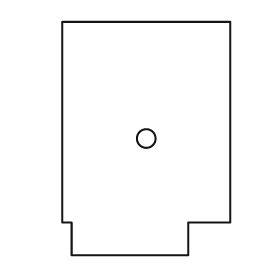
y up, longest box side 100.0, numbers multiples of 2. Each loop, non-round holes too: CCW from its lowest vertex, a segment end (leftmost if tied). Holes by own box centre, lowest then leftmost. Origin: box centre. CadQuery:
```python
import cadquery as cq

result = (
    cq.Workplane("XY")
    .moveTo(-32.0, -50.0)
    .lineTo(18.0, -50.0)
    .lineTo(18.0, -36.0)
    .lineTo(36.0, -36.0)
    .lineTo(36.0, 50.0)
    .lineTo(-36.0, 50.0)
    .lineTo(-36.0, -36.0)
    .lineTo(-32.0, -36.0)
    .close()
    .moveTo(0.0, 0.0)
    .circle(4.0)
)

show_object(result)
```